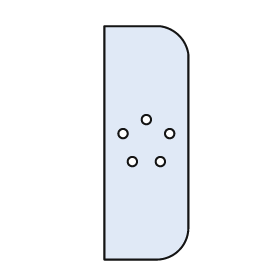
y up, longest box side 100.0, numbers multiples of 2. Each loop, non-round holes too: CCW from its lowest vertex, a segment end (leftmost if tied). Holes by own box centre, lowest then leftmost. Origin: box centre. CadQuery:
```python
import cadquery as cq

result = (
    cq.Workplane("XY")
    .moveTo(-18.0, -50.0)
    .lineTo(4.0, -50.0)
    .threePointArc((14.0, -46.0), (18.0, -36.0))
    .lineTo(18.0, 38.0)
    .threePointArc((14.0, 46.0), (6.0, 50.0))
    .lineTo(-18.0, 50.0)
    .close()
    .moveTo(-6.0, -8.0)
    .circle(2.0)
    .moveTo(6.0, -8.0)
    .circle(2.0)
    .moveTo(-10.0, 4.0)
    .circle(2.0)
    .moveTo(10.0, 4.0)
    .circle(2.0)
    .moveTo(0.0, 10.0)
    .circle(2.0)
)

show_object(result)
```